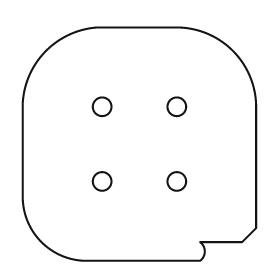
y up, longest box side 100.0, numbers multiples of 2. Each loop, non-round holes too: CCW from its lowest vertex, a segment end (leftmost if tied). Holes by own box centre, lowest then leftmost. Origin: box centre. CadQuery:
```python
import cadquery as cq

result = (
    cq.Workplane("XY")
    .moveTo(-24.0, -50.0)
    .lineTo(26.0, -50.0)
    .threePointArc((28.0, -46.0), (26.0, -42.0))
    .lineTo(44.0, -42.0)
    .lineTo(50.0, -36.0)
    .lineTo(50.0, 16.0)
    .threePointArc((40.0, 40.0), (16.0, 50.0))
    .lineTo(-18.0, 50.0)
    .threePointArc((-40.0, 40.0), (-50.0, 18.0))
    .lineTo(-50.0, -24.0)
    .threePointArc((-42.0, -42.0), (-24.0, -50.0))
    .close()
    .moveTo(-16.0, -16.0)
    .circle(4.0)
    .moveTo(16.0, -16.0)
    .circle(4.0)
    .moveTo(-16.0, 16.0)
    .circle(4.0)
    .moveTo(16.0, 16.0)
    .circle(4.0)
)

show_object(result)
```